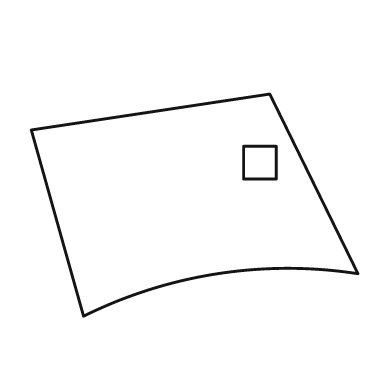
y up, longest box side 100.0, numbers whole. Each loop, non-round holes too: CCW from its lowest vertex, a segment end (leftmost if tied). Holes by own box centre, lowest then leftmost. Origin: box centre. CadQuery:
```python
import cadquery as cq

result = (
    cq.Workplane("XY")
    .moveTo(-34.0, -34.0)
    .threePointArc((7.0, -21.0), (50.0, -21.0))
    .lineTo(23.0, 34.0)
    .lineTo(-50.0, 23.0)
    .close()
    .moveTo(15.0, 8.0)
    .lineTo(25.0, 8.0)
    .lineTo(25.0, 18.0)
    .lineTo(15.0, 18.0)
    .close()
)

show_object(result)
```